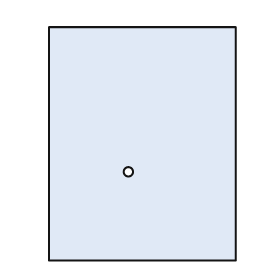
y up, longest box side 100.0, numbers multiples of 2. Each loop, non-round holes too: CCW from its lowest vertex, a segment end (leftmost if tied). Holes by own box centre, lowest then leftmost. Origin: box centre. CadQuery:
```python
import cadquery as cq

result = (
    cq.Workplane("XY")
    .moveTo(-40.0, -50.0)
    .lineTo(40.0, -50.0)
    .lineTo(40.0, 50.0)
    .lineTo(-40.0, 50.0)
    .close()
    .moveTo(-6.0, -12.0)
    .circle(2.0)
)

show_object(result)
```